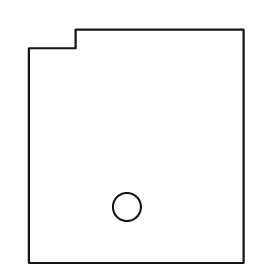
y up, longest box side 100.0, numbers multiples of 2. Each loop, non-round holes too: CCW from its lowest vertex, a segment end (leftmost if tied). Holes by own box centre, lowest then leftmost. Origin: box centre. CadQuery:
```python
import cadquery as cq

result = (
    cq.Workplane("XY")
    .moveTo(-46.0, -50.0)
    .lineTo(46.0, -50.0)
    .lineTo(46.0, 50.0)
    .lineTo(-26.0, 50.0)
    .lineTo(-26.0, 42.0)
    .lineTo(-46.0, 42.0)
    .close()
    .moveTo(-4.0, -26.0)
    .circle(6.0)
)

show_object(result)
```